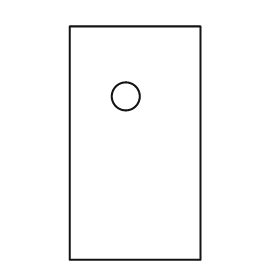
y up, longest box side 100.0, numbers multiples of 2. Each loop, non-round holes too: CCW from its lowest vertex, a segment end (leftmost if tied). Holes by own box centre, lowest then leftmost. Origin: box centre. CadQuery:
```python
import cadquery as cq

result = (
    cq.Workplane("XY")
    .moveTo(-28.0, -50.0)
    .lineTo(28.0, -50.0)
    .lineTo(28.0, 50.0)
    .lineTo(-28.0, 50.0)
    .close()
    .moveTo(-4.0, 20.0)
    .circle(6.0)
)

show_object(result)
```